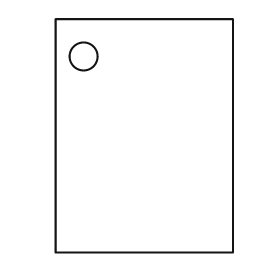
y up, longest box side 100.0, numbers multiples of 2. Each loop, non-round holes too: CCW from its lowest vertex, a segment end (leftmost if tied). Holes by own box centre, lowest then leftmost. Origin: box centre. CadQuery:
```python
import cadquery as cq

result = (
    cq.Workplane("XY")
    .moveTo(-38.0, -50.0)
    .lineTo(38.0, -50.0)
    .lineTo(38.0, 50.0)
    .lineTo(-38.0, 50.0)
    .close()
    .moveTo(-26.0, 34.0)
    .circle(6.0)
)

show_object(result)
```